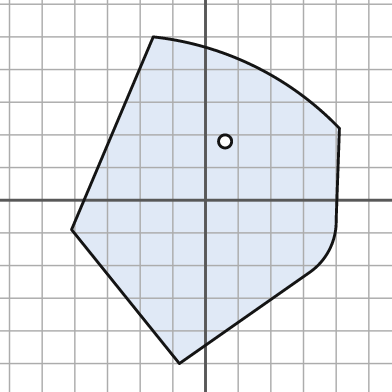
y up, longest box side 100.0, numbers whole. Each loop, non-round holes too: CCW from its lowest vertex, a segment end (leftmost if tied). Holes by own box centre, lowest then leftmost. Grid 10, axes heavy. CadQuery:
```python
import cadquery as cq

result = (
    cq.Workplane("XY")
    .moveTo(-8.0, -50.0)
    .lineTo(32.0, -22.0)
    .threePointArc((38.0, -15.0), (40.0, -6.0))
    .lineTo(41.0, 22.0)
    .threePointArc((15.0, 41.0), (-16.0, 50.0))
    .lineTo(-41.0, -9.0)
    .close()
    .moveTo(6.0, 18.0)
    .circle(2.0)
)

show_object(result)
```